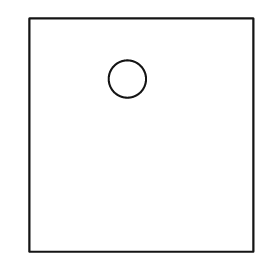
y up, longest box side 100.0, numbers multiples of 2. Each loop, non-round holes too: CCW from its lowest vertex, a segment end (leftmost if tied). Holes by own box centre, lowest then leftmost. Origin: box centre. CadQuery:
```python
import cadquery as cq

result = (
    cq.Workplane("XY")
    .moveTo(-48.0, -50.0)
    .lineTo(48.0, -50.0)
    .lineTo(48.0, 50.0)
    .lineTo(-48.0, 50.0)
    .close()
    .moveTo(-6.0, 24.0)
    .circle(8.0)
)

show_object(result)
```